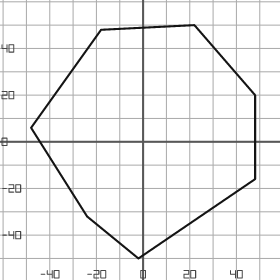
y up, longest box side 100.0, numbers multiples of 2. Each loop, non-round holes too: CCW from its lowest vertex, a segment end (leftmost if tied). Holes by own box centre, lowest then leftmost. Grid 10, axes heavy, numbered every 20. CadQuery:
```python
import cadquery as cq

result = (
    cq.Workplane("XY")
    .moveTo(-2.0, -50.0)
    .lineTo(48.0, -16.0)
    .lineTo(48.0, 20.0)
    .lineTo(22.0, 50.0)
    .lineTo(-18.0, 48.0)
    .lineTo(-48.0, 6.0)
    .lineTo(-24.0, -32.0)
    .close()
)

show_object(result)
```